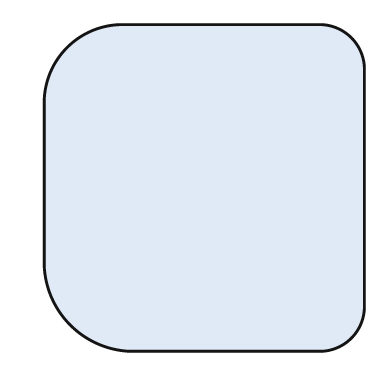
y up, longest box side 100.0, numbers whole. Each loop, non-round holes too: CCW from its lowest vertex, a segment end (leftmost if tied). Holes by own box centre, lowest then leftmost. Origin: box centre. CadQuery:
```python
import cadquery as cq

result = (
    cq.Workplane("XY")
    .moveTo(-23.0, -50.0)
    .lineTo(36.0, -50.0)
    .threePointArc((45.0, -46.0), (49.0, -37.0))
    .lineTo(49.0, 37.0)
    .threePointArc((45.0, 46.0), (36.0, 50.0))
    .lineTo(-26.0, 50.0)
    .threePointArc((-42.0, 43.0), (-49.0, 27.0))
    .lineTo(-49.0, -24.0)
    .threePointArc((-41.0, -42.0), (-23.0, -50.0))
    .close()
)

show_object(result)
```